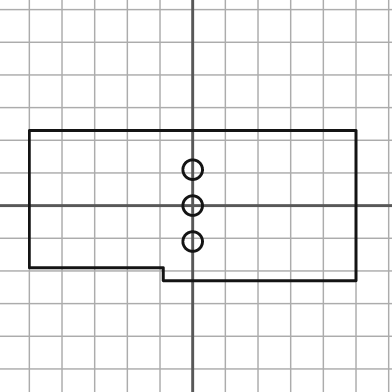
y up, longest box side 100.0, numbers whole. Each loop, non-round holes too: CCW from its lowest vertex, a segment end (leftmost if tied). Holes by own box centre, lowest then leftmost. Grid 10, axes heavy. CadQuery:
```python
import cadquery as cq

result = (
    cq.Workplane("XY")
    .moveTo(-9.0, -23.0)
    .lineTo(50.0, -23.0)
    .lineTo(50.0, 23.0)
    .lineTo(-50.0, 23.0)
    .lineTo(-50.0, -19.0)
    .lineTo(-9.0, -19.0)
    .close()
    .moveTo(0.0, -11.0)
    .circle(3.0)
    .moveTo(0.0, 0.0)
    .circle(3.0)
    .moveTo(0.0, 11.0)
    .circle(3.0)
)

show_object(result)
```